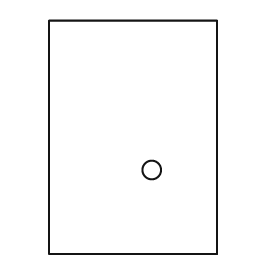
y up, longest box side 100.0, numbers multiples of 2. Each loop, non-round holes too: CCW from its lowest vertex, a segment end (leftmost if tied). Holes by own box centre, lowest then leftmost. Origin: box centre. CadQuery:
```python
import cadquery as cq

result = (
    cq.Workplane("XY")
    .moveTo(-36.0, -50.0)
    .lineTo(36.0, -50.0)
    .lineTo(36.0, 50.0)
    .lineTo(-36.0, 50.0)
    .close()
    .moveTo(8.0, -14.0)
    .circle(4.0)
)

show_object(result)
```